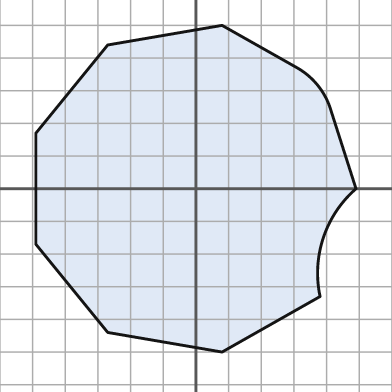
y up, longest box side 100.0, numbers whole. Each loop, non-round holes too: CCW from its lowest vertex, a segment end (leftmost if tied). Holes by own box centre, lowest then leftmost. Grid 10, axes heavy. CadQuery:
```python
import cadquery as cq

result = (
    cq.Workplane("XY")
    .moveTo(8.0, -50.0)
    .lineTo(38.0, -33.0)
    .threePointArc((39.0, -15.0), (49.0, 0.0))
    .lineTo(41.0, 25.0)
    .threePointArc((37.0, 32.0), (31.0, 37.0))
    .lineTo(8.0, 50.0)
    .lineTo(-27.0, 44.0)
    .lineTo(-49.0, 17.0)
    .lineTo(-49.0, -17.0)
    .lineTo(-27.0, -44.0)
    .close()
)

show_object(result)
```